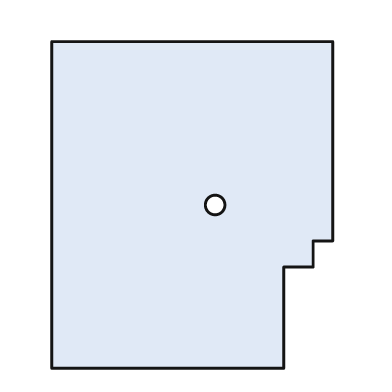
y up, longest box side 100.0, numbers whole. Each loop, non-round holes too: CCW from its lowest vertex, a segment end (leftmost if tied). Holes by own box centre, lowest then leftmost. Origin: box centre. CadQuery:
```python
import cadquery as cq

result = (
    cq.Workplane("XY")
    .moveTo(-43.0, -50.0)
    .lineTo(28.0, -50.0)
    .lineTo(28.0, -19.0)
    .lineTo(37.0, -19.0)
    .lineTo(37.0, -11.0)
    .lineTo(43.0, -11.0)
    .lineTo(43.0, 50.0)
    .lineTo(-43.0, 50.0)
    .close()
    .moveTo(7.0, 0.0)
    .circle(3.0)
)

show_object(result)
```